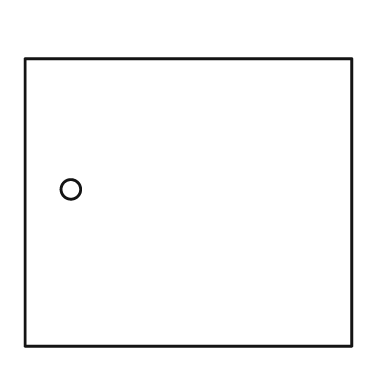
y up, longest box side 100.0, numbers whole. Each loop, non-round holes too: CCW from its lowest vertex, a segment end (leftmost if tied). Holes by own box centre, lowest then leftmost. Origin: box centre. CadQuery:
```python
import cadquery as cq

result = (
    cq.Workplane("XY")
    .moveTo(-50.0, -44.0)
    .lineTo(50.0, -44.0)
    .lineTo(50.0, 44.0)
    .lineTo(-50.0, 44.0)
    .close()
    .moveTo(-36.0, 4.0)
    .circle(3.0)
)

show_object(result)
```